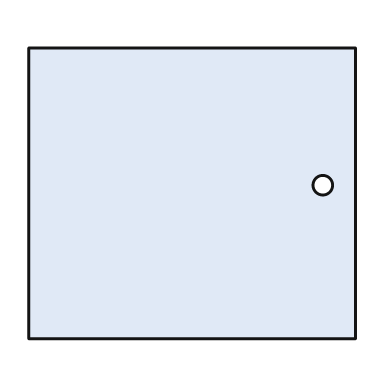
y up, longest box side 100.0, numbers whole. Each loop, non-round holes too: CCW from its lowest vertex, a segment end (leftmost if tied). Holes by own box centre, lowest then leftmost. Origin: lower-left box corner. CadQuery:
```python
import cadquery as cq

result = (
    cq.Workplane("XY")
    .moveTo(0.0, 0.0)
    .lineTo(100.0, 0.0)
    .lineTo(100.0, 89.0)
    .lineTo(0.0, 89.0)
    .close()
    .moveTo(90.0, 47.0)
    .circle(3.0)
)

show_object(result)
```